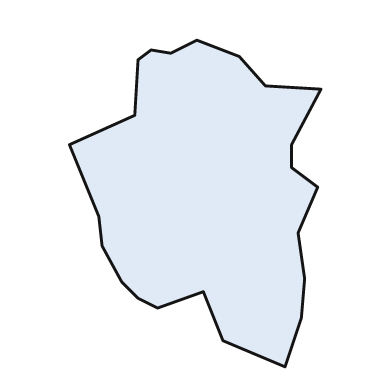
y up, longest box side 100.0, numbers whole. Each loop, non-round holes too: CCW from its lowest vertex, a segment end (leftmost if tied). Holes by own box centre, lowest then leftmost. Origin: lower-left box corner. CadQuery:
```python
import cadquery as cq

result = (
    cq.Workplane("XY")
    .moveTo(66.0, 0.0)
    .lineTo(71.0, 15.0)
    .lineTo(72.0, 27.0)
    .lineTo(70.0, 41.0)
    .lineTo(76.0, 55.0)
    .lineTo(68.0, 61.0)
    .lineTo(68.0, 68.0)
    .lineTo(77.0, 85.0)
    .lineTo(60.0, 86.0)
    .lineTo(52.0, 95.0)
    .lineTo(39.0, 100.0)
    .lineTo(31.0, 96.0)
    .lineTo(25.0, 97.0)
    .lineTo(21.0, 94.0)
    .lineTo(20.0, 77.0)
    .lineTo(0.0, 68.0)
    .lineTo(9.0, 46.0)
    .lineTo(10.0, 37.0)
    .lineTo(16.0, 26.0)
    .lineTo(21.0, 21.0)
    .lineTo(27.0, 18.0)
    .lineTo(41.0, 23.0)
    .lineTo(47.0, 8.0)
    .close()
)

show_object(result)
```